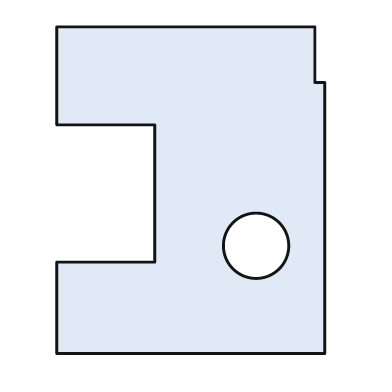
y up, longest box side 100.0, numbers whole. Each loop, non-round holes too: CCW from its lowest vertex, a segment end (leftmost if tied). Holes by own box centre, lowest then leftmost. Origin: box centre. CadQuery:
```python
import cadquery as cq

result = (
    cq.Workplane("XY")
    .moveTo(-41.0, -50.0)
    .lineTo(41.0, -50.0)
    .lineTo(41.0, 33.0)
    .lineTo(38.0, 33.0)
    .lineTo(38.0, 50.0)
    .lineTo(-41.0, 50.0)
    .lineTo(-41.0, 20.0)
    .lineTo(-11.0, 20.0)
    .lineTo(-11.0, -22.0)
    .lineTo(-41.0, -22.0)
    .close()
    .moveTo(20.0, -17.0)
    .circle(10.0)
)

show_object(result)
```